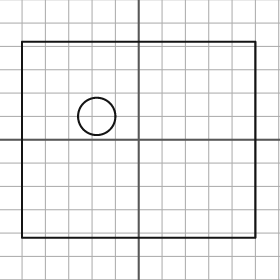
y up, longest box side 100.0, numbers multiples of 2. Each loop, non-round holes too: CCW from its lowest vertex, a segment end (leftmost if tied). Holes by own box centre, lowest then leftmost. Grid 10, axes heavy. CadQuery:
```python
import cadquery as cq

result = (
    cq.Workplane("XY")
    .moveTo(-50.0, -42.0)
    .lineTo(50.0, -42.0)
    .lineTo(50.0, 42.0)
    .lineTo(-50.0, 42.0)
    .close()
    .moveTo(-18.0, 10.0)
    .circle(8.0)
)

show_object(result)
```